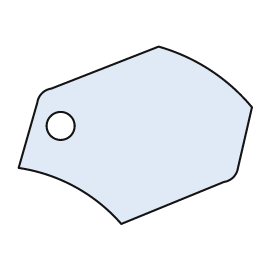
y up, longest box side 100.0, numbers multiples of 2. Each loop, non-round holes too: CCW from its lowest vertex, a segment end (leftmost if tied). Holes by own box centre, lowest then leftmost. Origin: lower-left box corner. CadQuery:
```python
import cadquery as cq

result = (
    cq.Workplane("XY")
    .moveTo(44.0, 0.0)
    .lineTo(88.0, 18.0)
    .threePointArc((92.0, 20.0), (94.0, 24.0))
    .lineTo(100.0, 50.0)
    .threePointArc((82.0, 66.0), (60.0, 76.0))
    .lineTo(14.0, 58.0)
    .threePointArc((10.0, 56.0), (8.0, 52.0))
    .lineTo(0.0, 24.0)
    .threePointArc((24.0, 16.0), (44.0, 0.0))
    .close()
    .moveTo(18.0, 42.0)
    .circle(6.0)
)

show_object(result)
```